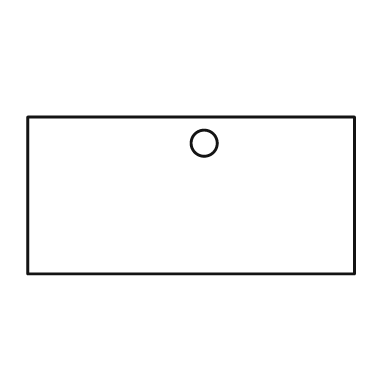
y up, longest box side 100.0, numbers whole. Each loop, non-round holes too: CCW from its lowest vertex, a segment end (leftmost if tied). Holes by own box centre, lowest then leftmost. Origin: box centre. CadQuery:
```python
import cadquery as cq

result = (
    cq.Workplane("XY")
    .moveTo(-50.0, -24.0)
    .lineTo(50.0, -24.0)
    .lineTo(50.0, 24.0)
    .lineTo(-50.0, 24.0)
    .close()
    .moveTo(4.0, 16.0)
    .circle(4.0)
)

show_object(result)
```